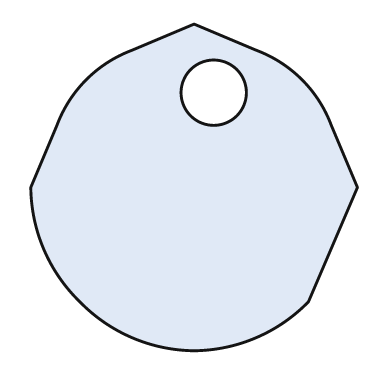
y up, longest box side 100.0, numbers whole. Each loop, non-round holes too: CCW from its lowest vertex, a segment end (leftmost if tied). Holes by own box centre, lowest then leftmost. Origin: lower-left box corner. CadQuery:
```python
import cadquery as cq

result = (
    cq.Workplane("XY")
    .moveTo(50.0, 0.0)
    .threePointArc((69.0, 4.0), (85.0, 15.0))
    .lineTo(100.0, 50.0)
    .lineTo(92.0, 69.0)
    .threePointArc((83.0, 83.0), (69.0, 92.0))
    .lineTo(50.0, 100.0)
    .lineTo(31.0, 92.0)
    .threePointArc((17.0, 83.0), (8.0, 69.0))
    .lineTo(0.0, 50.0)
    .threePointArc((4.0, 31.0), (15.0, 15.0))
    .threePointArc((31.0, 4.0), (50.0, 0.0))
    .close()
    .moveTo(56.0, 79.0)
    .circle(10.0)
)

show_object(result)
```